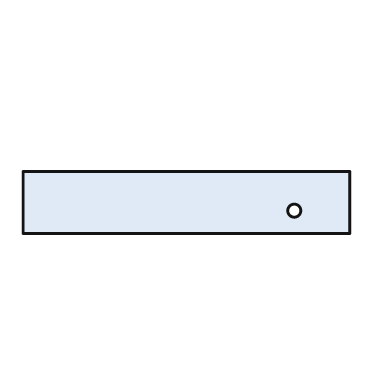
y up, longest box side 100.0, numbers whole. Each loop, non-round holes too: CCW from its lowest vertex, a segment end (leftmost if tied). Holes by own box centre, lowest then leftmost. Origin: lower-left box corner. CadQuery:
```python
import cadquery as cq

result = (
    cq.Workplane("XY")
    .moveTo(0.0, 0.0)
    .lineTo(100.0, 0.0)
    .lineTo(100.0, 19.0)
    .lineTo(0.0, 19.0)
    .close()
    .moveTo(83.0, 7.0)
    .circle(2.0)
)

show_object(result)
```